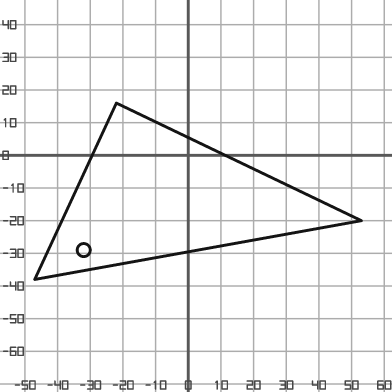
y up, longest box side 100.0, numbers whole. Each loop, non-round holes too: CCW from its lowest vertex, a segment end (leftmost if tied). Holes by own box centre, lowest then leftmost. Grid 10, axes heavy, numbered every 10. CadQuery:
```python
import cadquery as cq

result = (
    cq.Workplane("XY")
    .moveTo(-47.0, -38.0)
    .lineTo(53.0, -20.0)
    .lineTo(-22.0, 16.0)
    .close()
    .moveTo(-32.0, -29.0)
    .circle(2.0)
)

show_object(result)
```